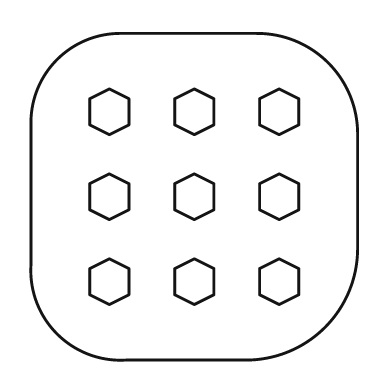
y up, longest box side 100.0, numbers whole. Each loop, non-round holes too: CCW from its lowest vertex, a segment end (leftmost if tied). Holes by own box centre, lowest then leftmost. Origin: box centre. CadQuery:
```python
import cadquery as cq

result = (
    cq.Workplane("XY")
    .moveTo(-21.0, -50.0)
    .lineTo(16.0, -50.0)
    .threePointArc((40.0, -40.0), (50.0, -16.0))
    .lineTo(50.0, 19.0)
    .threePointArc((41.0, 41.0), (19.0, 50.0))
    .lineTo(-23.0, 50.0)
    .threePointArc((-42.0, 42.0), (-50.0, 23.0))
    .lineTo(-50.0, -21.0)
    .threePointArc((-42.0, -42.0), (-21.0, -50.0))
    .close()
    .moveTo(-26.0, -33.0)
    .lineTo(-20.0, -30.0)
    .lineTo(-20.0, -22.0)
    .lineTo(-26.0, -19.0)
    .lineTo(-32.0, -22.0)
    .lineTo(-32.0, -30.0)
    .close()
    .moveTo(0.0, -33.0)
    .lineTo(6.0, -30.0)
    .lineTo(6.0, -22.0)
    .lineTo(0.0, -19.0)
    .lineTo(-6.0, -22.0)
    .lineTo(-6.0, -30.0)
    .close()
    .moveTo(26.0, -33.0)
    .lineTo(32.0, -30.0)
    .lineTo(32.0, -22.0)
    .lineTo(26.0, -19.0)
    .lineTo(20.0, -22.0)
    .lineTo(20.0, -30.0)
    .close()
    .moveTo(-26.0, -7.0)
    .lineTo(-20.0, -4.0)
    .lineTo(-20.0, 4.0)
    .lineTo(-26.0, 7.0)
    .lineTo(-32.0, 4.0)
    .lineTo(-32.0, -4.0)
    .close()
    .moveTo(0.0, -7.0)
    .lineTo(6.0, -4.0)
    .lineTo(6.0, 4.0)
    .lineTo(0.0, 7.0)
    .lineTo(-6.0, 4.0)
    .lineTo(-6.0, -4.0)
    .close()
    .moveTo(26.0, -7.0)
    .lineTo(32.0, -4.0)
    .lineTo(32.0, 4.0)
    .lineTo(26.0, 7.0)
    .lineTo(20.0, 4.0)
    .lineTo(20.0, -4.0)
    .close()
    .moveTo(-26.0, 19.0)
    .lineTo(-20.0, 22.0)
    .lineTo(-20.0, 30.0)
    .lineTo(-26.0, 33.0)
    .lineTo(-32.0, 30.0)
    .lineTo(-32.0, 22.0)
    .close()
    .moveTo(0.0, 19.0)
    .lineTo(6.0, 22.0)
    .lineTo(6.0, 30.0)
    .lineTo(0.0, 33.0)
    .lineTo(-6.0, 30.0)
    .lineTo(-6.0, 22.0)
    .close()
    .moveTo(26.0, 19.0)
    .lineTo(32.0, 22.0)
    .lineTo(32.0, 30.0)
    .lineTo(26.0, 33.0)
    .lineTo(20.0, 30.0)
    .lineTo(20.0, 22.0)
    .close()
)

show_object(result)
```